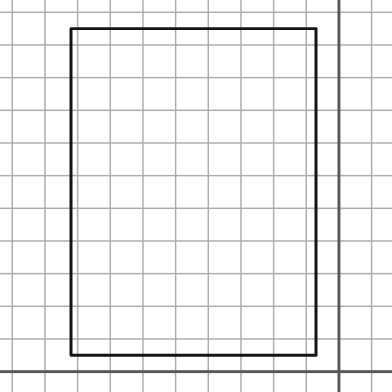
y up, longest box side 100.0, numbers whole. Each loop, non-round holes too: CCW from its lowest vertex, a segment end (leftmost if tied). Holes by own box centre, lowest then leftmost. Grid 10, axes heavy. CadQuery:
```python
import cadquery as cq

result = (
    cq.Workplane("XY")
    .moveTo(-82.0, 5.0)
    .lineTo(-7.0, 5.0)
    .lineTo(-7.0, 105.0)
    .lineTo(-82.0, 105.0)
    .close()
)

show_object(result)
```